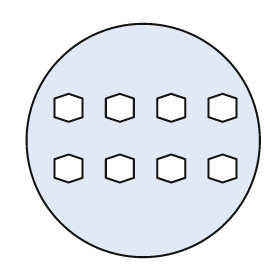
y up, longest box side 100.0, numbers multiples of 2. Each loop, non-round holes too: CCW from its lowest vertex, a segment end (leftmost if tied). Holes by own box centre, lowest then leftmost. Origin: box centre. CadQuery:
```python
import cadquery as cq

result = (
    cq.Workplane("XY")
    .moveTo(0.0, 0.0)
    .circle(50.0)
    .moveTo(-32.0, -18.0)
    .lineTo(-26.0, -16.0)
    .lineTo(-26.0, -8.0)
    .lineTo(-32.0, -6.0)
    .lineTo(-38.0, -8.0)
    .lineTo(-38.0, -16.0)
    .close()
    .moveTo(-10.0, -18.0)
    .lineTo(-4.0, -16.0)
    .lineTo(-4.0, -8.0)
    .lineTo(-10.0, -6.0)
    .lineTo(-16.0, -8.0)
    .lineTo(-16.0, -16.0)
    .close()
    .moveTo(12.0, -18.0)
    .lineTo(18.0, -16.0)
    .lineTo(18.0, -8.0)
    .lineTo(12.0, -6.0)
    .lineTo(6.0, -8.0)
    .lineTo(6.0, -16.0)
    .close()
    .moveTo(34.0, -18.0)
    .lineTo(40.0, -16.0)
    .lineTo(40.0, -8.0)
    .lineTo(34.0, -6.0)
    .lineTo(28.0, -8.0)
    .lineTo(28.0, -16.0)
    .close()
    .moveTo(-32.0, 8.0)
    .lineTo(-26.0, 10.0)
    .lineTo(-26.0, 18.0)
    .lineTo(-32.0, 20.0)
    .lineTo(-38.0, 18.0)
    .lineTo(-38.0, 10.0)
    .close()
    .moveTo(-10.0, 8.0)
    .lineTo(-4.0, 10.0)
    .lineTo(-4.0, 18.0)
    .lineTo(-10.0, 20.0)
    .lineTo(-16.0, 18.0)
    .lineTo(-16.0, 10.0)
    .close()
    .moveTo(12.0, 8.0)
    .lineTo(18.0, 10.0)
    .lineTo(18.0, 18.0)
    .lineTo(12.0, 20.0)
    .lineTo(6.0, 18.0)
    .lineTo(6.0, 10.0)
    .close()
    .moveTo(34.0, 8.0)
    .lineTo(40.0, 10.0)
    .lineTo(40.0, 18.0)
    .lineTo(34.0, 20.0)
    .lineTo(28.0, 18.0)
    .lineTo(28.0, 10.0)
    .close()
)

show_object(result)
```